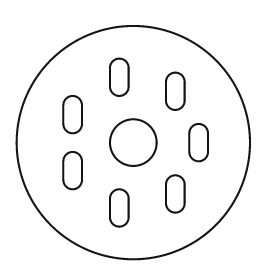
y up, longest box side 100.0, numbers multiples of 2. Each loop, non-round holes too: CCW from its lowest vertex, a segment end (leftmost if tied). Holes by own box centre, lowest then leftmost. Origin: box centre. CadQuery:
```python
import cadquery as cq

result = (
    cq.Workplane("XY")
    .moveTo(0.0, 0.0)
    .circle(50.0)
    .moveTo(-10.0, -32.0)
    .threePointArc((-6.0, -36.0), (-2.0, -32.0))
    .lineTo(-2.0, -24.0)
    .threePointArc((-6.0, -20.0), (-10.0, -24.0))
    .close()
    .moveTo(14.0, -26.0)
    .threePointArc((18.0, -30.0), (22.0, -26.0))
    .lineTo(22.0, -18.0)
    .threePointArc((18.0, -14.0), (14.0, -18.0))
    .close()
    .moveTo(-30.0, -16.0)
    .threePointArc((-26.0, -20.0), (-22.0, -16.0))
    .lineTo(-22.0, -8.0)
    .threePointArc((-26.0, -4.0), (-30.0, -8.0))
    .close()
    .moveTo(0.0, 0.0)
    .circle(10.0)
    .moveTo(24.0, -4.0)
    .threePointArc((28.0, -8.0), (32.0, -4.0))
    .lineTo(32.0, 4.0)
    .threePointArc((28.0, 8.0), (24.0, 4.0))
    .close()
    .moveTo(-30.0, 8.0)
    .threePointArc((-26.0, 4.0), (-22.0, 8.0))
    .lineTo(-22.0, 16.0)
    .threePointArc((-26.0, 20.0), (-30.0, 16.0))
    .close()
    .moveTo(14.0, 18.0)
    .threePointArc((18.0, 14.0), (22.0, 18.0))
    .lineTo(22.0, 26.0)
    .threePointArc((18.0, 30.0), (14.0, 26.0))
    .close()
    .moveTo(-10.0, 24.0)
    .threePointArc((-6.0, 20.0), (-2.0, 24.0))
    .lineTo(-2.0, 32.0)
    .threePointArc((-6.0, 36.0), (-10.0, 32.0))
    .close()
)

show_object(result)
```